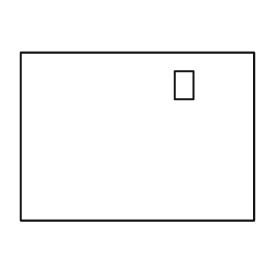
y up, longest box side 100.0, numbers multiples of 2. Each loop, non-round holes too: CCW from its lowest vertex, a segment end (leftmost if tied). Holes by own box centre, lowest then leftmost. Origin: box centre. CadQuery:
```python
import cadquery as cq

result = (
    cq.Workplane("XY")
    .moveTo(-50.0, -36.0)
    .lineTo(50.0, -36.0)
    .lineTo(50.0, 36.0)
    .lineTo(-50.0, 36.0)
    .close()
    .moveTo(16.0, 16.0)
    .lineTo(24.0, 16.0)
    .lineTo(24.0, 28.0)
    .lineTo(16.0, 28.0)
    .close()
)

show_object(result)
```